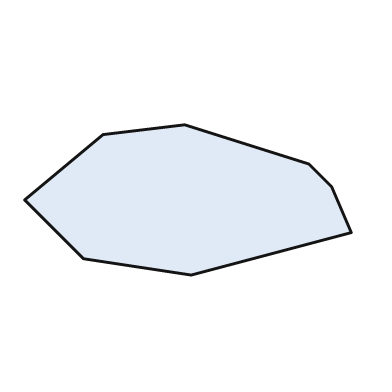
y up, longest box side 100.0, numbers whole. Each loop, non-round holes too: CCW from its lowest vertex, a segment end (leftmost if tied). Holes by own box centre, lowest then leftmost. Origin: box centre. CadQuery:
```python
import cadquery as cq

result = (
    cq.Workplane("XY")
    .moveTo(1.0, -23.0)
    .lineTo(50.0, -10.0)
    .lineTo(44.0, 4.0)
    .lineTo(37.0, 11.0)
    .lineTo(-1.0, 23.0)
    .lineTo(-26.0, 20.0)
    .lineTo(-50.0, 0.0)
    .lineTo(-32.0, -18.0)
    .close()
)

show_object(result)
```